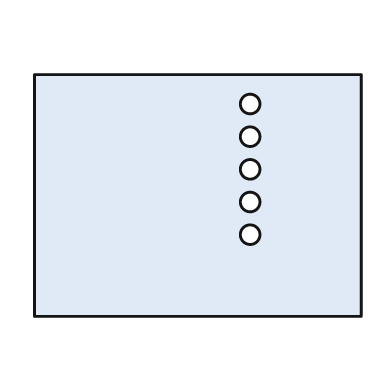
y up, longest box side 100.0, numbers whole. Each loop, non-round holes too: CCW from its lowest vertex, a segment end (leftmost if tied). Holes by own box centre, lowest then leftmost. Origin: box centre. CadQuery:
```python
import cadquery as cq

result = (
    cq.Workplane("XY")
    .moveTo(-50.0, -37.0)
    .lineTo(50.0, -37.0)
    .lineTo(50.0, 37.0)
    .lineTo(-50.0, 37.0)
    .close()
    .moveTo(16.0, -12.0)
    .circle(3.0)
    .moveTo(16.0, -2.0)
    .circle(3.0)
    .moveTo(16.0, 8.0)
    .circle(3.0)
    .moveTo(16.0, 18.0)
    .circle(3.0)
    .moveTo(16.0, 28.0)
    .circle(3.0)
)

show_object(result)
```